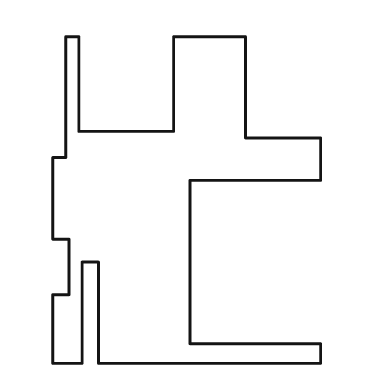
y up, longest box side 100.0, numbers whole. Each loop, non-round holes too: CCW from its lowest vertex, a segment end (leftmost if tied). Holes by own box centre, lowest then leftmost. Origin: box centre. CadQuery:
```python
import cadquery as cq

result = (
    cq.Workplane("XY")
    .moveTo(-41.0, -50.0)
    .lineTo(-32.0, -50.0)
    .lineTo(-32.0, -19.0)
    .lineTo(-27.0, -19.0)
    .lineTo(-27.0, -50.0)
    .lineTo(41.0, -50.0)
    .lineTo(41.0, -44.0)
    .lineTo(1.0, -44.0)
    .lineTo(1.0, 6.0)
    .lineTo(41.0, 6.0)
    .lineTo(41.0, 19.0)
    .lineTo(18.0, 19.0)
    .lineTo(18.0, 50.0)
    .lineTo(-4.0, 50.0)
    .lineTo(-4.0, 21.0)
    .lineTo(-33.0, 21.0)
    .lineTo(-33.0, 50.0)
    .lineTo(-37.0, 50.0)
    .lineTo(-37.0, 13.0)
    .lineTo(-41.0, 13.0)
    .lineTo(-41.0, -12.0)
    .lineTo(-36.0, -12.0)
    .lineTo(-36.0, -29.0)
    .lineTo(-41.0, -29.0)
    .close()
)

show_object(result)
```